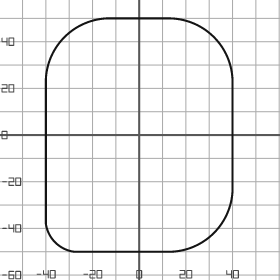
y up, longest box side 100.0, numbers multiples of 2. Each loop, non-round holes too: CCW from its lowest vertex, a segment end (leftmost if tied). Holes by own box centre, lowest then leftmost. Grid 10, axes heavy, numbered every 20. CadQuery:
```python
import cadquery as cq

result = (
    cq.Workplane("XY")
    .moveTo(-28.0, -50.0)
    .lineTo(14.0, -50.0)
    .threePointArc((32.0, -42.0), (40.0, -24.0))
    .lineTo(40.0, 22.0)
    .threePointArc((32.0, 42.0), (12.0, 50.0))
    .lineTo(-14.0, 50.0)
    .threePointArc((-32.0, 42.0), (-40.0, 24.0))
    .lineTo(-40.0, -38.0)
    .threePointArc((-36.0, -46.0), (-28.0, -50.0))
    .close()
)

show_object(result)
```